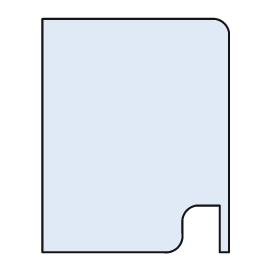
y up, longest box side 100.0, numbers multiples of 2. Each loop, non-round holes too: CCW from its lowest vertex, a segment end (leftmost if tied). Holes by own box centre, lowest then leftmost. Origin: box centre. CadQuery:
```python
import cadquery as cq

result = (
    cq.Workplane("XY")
    .moveTo(-40.0, -50.0)
    .lineTo(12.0, -50.0)
    .threePointArc((18.0, -48.0), (20.0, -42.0))
    .lineTo(20.0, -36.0)
    .threePointArc((22.0, -32.0), (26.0, -30.0))
    .lineTo(36.0, -30.0)
    .lineTo(36.0, -50.0)
    .lineTo(40.0, -50.0)
    .lineTo(40.0, 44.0)
    .threePointArc((38.0, 48.0), (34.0, 50.0))
    .lineTo(-40.0, 50.0)
    .close()
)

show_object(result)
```